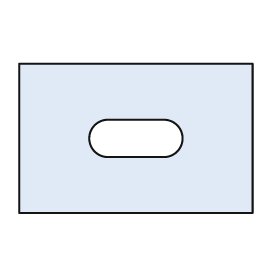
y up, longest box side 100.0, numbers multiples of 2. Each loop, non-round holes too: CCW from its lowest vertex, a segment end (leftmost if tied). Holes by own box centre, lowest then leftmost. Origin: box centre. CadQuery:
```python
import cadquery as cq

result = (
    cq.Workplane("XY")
    .moveTo(-50.0, -32.0)
    .lineTo(50.0, -32.0)
    .lineTo(50.0, 32.0)
    .lineTo(-50.0, 32.0)
    .close()
    .moveTo(-12.0, -8.0)
    .lineTo(12.0, -8.0)
    .threePointArc((20.0, 0.0), (12.0, 8.0))
    .lineTo(-12.0, 8.0)
    .threePointArc((-20.0, 0.0), (-12.0, -8.0))
    .close()
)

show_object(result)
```